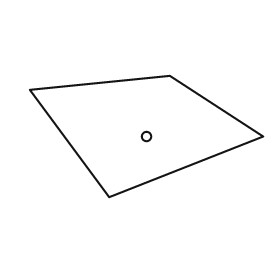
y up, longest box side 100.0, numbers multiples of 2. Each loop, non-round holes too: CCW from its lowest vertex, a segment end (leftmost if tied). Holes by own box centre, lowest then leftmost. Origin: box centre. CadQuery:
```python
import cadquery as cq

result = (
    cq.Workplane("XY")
    .moveTo(-16.0, -26.0)
    .lineTo(50.0, 0.0)
    .lineTo(10.0, 26.0)
    .lineTo(-50.0, 20.0)
    .close()
    .moveTo(0.0, 0.0)
    .circle(2.0)
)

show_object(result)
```